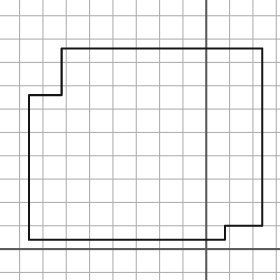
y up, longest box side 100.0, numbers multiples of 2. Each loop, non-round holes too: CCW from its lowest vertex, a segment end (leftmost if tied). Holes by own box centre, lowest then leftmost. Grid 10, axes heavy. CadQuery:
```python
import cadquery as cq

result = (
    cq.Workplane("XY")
    .moveTo(-76.0, 4.0)
    .lineTo(8.0, 4.0)
    .lineTo(8.0, 10.0)
    .lineTo(24.0, 10.0)
    .lineTo(24.0, 86.0)
    .lineTo(-62.0, 86.0)
    .lineTo(-62.0, 66.0)
    .lineTo(-76.0, 66.0)
    .close()
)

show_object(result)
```